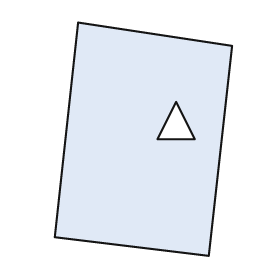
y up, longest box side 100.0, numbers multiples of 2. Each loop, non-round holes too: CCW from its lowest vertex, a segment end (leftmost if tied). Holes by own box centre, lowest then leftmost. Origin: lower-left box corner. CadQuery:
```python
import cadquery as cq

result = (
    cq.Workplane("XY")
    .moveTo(66.0, 0.0)
    .lineTo(76.0, 90.0)
    .lineTo(10.0, 100.0)
    .lineTo(0.0, 8.0)
    .close()
    .moveTo(44.0, 50.0)
    .lineTo(60.0, 50.0)
    .lineTo(52.0, 66.0)
    .close()
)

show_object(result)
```